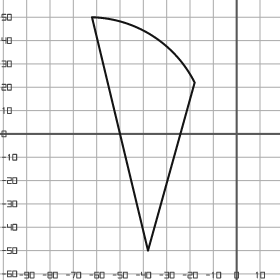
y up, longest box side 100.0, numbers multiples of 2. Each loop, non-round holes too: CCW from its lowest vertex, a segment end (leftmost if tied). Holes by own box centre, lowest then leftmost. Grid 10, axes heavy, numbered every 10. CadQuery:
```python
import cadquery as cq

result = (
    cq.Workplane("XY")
    .moveTo(-38.0, -50.0)
    .lineTo(-18.0, 22.0)
    .threePointArc((-36.0, 42.0), (-62.0, 50.0))
    .close()
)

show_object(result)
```